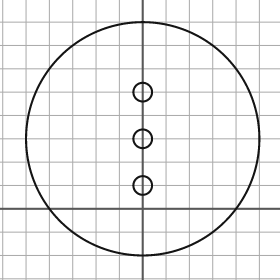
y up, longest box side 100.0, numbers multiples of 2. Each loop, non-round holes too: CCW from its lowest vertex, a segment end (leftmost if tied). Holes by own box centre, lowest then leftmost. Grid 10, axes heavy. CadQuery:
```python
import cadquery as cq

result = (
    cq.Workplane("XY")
    .moveTo(0.0, 30.0)
    .circle(50.0)
    .moveTo(0.0, 10.0)
    .circle(4.0)
    .moveTo(0.0, 30.0)
    .circle(4.0)
    .moveTo(0.0, 50.0)
    .circle(4.0)
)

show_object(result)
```